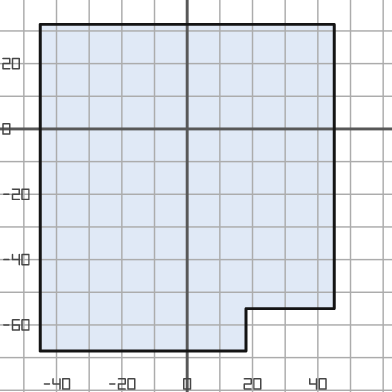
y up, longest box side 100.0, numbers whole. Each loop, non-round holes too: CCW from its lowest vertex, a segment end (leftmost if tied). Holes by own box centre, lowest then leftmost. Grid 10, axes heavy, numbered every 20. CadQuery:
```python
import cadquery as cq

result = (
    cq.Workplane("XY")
    .moveTo(-45.0, -68.0)
    .lineTo(18.0, -68.0)
    .lineTo(18.0, -55.0)
    .lineTo(45.0, -55.0)
    .lineTo(45.0, 32.0)
    .lineTo(-45.0, 32.0)
    .close()
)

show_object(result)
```